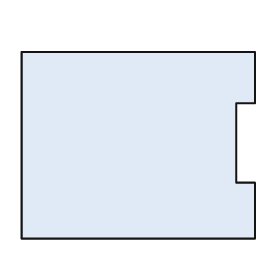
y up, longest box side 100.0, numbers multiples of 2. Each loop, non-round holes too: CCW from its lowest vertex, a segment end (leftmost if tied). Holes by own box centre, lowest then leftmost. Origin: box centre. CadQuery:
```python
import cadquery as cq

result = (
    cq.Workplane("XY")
    .moveTo(-50.0, -40.0)
    .lineTo(50.0, -40.0)
    .lineTo(50.0, -16.0)
    .lineTo(42.0, -16.0)
    .lineTo(42.0, 18.0)
    .lineTo(50.0, 18.0)
    .lineTo(50.0, 40.0)
    .lineTo(-50.0, 40.0)
    .close()
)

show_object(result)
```